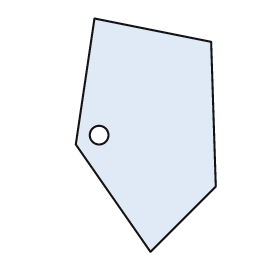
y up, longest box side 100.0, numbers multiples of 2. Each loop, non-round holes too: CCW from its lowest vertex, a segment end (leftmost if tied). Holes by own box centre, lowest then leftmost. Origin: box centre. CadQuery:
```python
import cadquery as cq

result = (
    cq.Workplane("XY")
    .moveTo(2.0, -50.0)
    .lineTo(30.0, -22.0)
    .lineTo(28.0, 40.0)
    .lineTo(-22.0, 50.0)
    .lineTo(-30.0, -4.0)
    .close()
    .moveTo(-20.0, 0.0)
    .circle(4.0)
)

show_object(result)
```